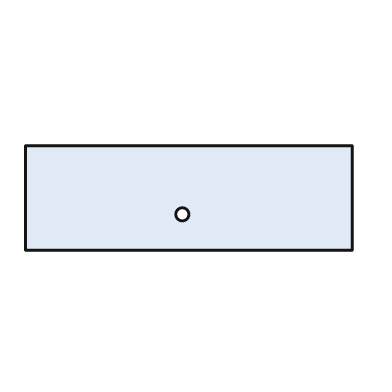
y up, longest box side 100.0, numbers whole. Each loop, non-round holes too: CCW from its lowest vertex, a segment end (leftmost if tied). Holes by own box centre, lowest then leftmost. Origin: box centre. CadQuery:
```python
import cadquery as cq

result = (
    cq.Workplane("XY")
    .moveTo(-50.0, -16.0)
    .lineTo(50.0, -16.0)
    .lineTo(50.0, 16.0)
    .lineTo(-50.0, 16.0)
    .close()
    .moveTo(-2.0, -5.0)
    .circle(2.0)
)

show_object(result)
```